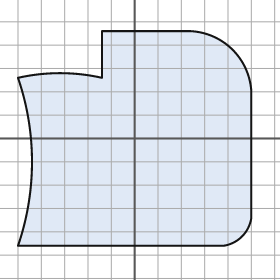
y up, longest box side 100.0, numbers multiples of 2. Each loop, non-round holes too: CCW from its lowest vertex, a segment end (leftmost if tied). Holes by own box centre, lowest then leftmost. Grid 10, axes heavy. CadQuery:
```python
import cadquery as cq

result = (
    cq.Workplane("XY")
    .moveTo(-50.0, -46.0)
    .lineTo(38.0, -46.0)
    .threePointArc((46.0, -42.0), (50.0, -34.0))
    .lineTo(50.0, 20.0)
    .threePointArc((42.0, 38.0), (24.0, 46.0))
    .lineTo(-14.0, 46.0)
    .lineTo(-14.0, 26.0)
    .threePointArc((-32.0, 28.0), (-50.0, 26.0))
    .threePointArc((-44.0, -10.0), (-50.0, -46.0))
    .close()
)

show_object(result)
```